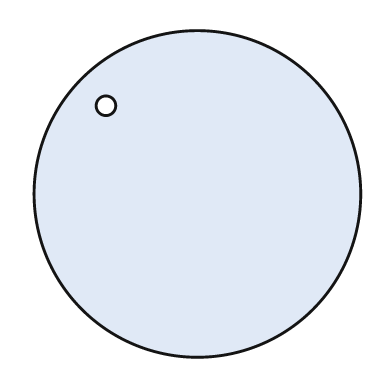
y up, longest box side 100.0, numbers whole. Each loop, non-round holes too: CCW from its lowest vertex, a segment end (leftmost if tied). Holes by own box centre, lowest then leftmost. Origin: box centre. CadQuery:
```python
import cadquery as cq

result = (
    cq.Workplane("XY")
    .moveTo(0.0, 0.0)
    .circle(50.0)
    .moveTo(-28.0, 27.0)
    .circle(3.0)
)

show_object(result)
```